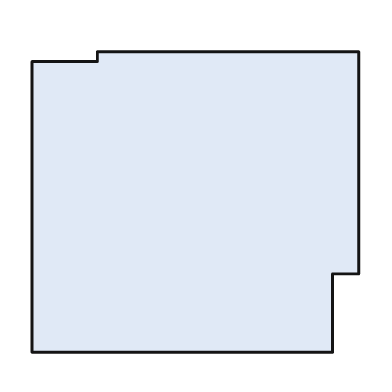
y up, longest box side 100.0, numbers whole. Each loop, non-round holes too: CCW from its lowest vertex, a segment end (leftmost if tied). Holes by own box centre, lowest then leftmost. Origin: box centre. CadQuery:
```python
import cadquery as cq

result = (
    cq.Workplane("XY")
    .moveTo(-50.0, -46.0)
    .lineTo(42.0, -46.0)
    .lineTo(42.0, -22.0)
    .lineTo(50.0, -22.0)
    .lineTo(50.0, 46.0)
    .lineTo(-30.0, 46.0)
    .lineTo(-30.0, 43.0)
    .lineTo(-50.0, 43.0)
    .close()
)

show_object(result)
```